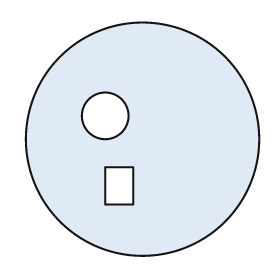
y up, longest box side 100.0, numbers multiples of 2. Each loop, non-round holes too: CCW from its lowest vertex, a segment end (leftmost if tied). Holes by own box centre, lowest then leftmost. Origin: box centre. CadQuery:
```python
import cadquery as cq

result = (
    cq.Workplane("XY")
    .moveTo(0.0, 0.0)
    .circle(50.0)
    .moveTo(-16.0, -28.0)
    .lineTo(-4.0, -28.0)
    .lineTo(-4.0, -12.0)
    .lineTo(-16.0, -12.0)
    .close()
    .moveTo(-16.0, 10.0)
    .circle(10.0)
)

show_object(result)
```